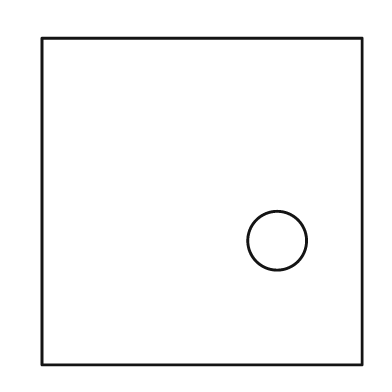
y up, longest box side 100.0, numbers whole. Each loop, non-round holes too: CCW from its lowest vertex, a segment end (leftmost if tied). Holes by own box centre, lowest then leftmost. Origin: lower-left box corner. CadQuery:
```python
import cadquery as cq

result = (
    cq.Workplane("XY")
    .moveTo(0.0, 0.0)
    .lineTo(98.0, 0.0)
    .lineTo(98.0, 100.0)
    .lineTo(0.0, 100.0)
    .close()
    .moveTo(72.0, 38.0)
    .circle(9.0)
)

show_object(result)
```